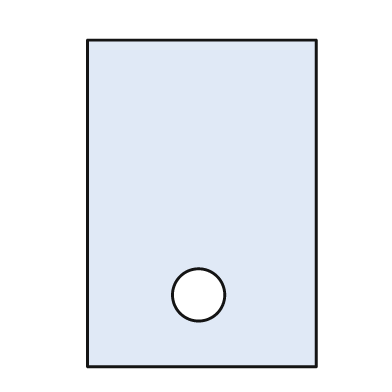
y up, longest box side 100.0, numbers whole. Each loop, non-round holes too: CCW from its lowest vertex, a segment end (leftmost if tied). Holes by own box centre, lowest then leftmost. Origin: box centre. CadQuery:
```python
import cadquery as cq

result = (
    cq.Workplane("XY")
    .moveTo(-35.0, -50.0)
    .lineTo(35.0, -50.0)
    .lineTo(35.0, 50.0)
    .lineTo(-35.0, 50.0)
    .close()
    .moveTo(-1.0, -28.0)
    .circle(8.0)
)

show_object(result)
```